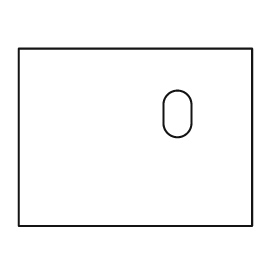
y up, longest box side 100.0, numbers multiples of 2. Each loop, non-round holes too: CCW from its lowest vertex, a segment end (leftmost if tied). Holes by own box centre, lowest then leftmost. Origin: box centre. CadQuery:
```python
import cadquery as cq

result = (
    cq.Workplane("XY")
    .moveTo(-50.0, -38.0)
    .lineTo(50.0, -38.0)
    .lineTo(50.0, 38.0)
    .lineTo(-50.0, 38.0)
    .close()
    .moveTo(12.0, 6.0)
    .threePointArc((18.0, 0.0), (24.0, 6.0))
    .lineTo(24.0, 14.0)
    .threePointArc((18.0, 20.0), (12.0, 14.0))
    .close()
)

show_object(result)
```